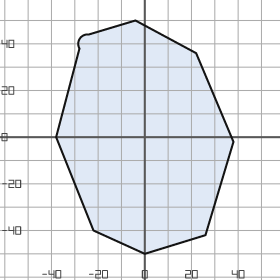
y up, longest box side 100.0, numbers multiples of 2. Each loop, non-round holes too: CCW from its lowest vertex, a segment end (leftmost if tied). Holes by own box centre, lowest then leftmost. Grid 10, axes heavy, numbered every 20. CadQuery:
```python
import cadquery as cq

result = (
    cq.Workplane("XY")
    .moveTo(0.0, -50.0)
    .lineTo(26.0, -42.0)
    .lineTo(38.0, -2.0)
    .lineTo(22.0, 36.0)
    .lineTo(-4.0, 50.0)
    .lineTo(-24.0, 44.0)
    .threePointArc((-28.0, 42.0), (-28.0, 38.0))
    .lineTo(-38.0, 0.0)
    .lineTo(-22.0, -40.0)
    .close()
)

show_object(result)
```